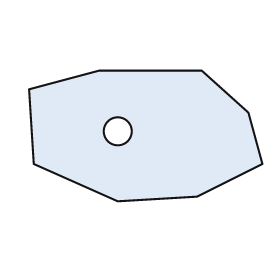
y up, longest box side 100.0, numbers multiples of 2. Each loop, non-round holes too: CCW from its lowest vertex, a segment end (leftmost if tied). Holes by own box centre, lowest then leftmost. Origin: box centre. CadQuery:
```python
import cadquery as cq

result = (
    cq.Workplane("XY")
    .moveTo(-12.0, -28.0)
    .lineTo(22.0, -26.0)
    .lineTo(50.0, -12.0)
    .lineTo(44.0, 10.0)
    .lineTo(24.0, 28.0)
    .lineTo(-20.0, 28.0)
    .lineTo(-50.0, 20.0)
    .lineTo(-48.0, -12.0)
    .close()
    .moveTo(-12.0, 2.0)
    .circle(6.0)
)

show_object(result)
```